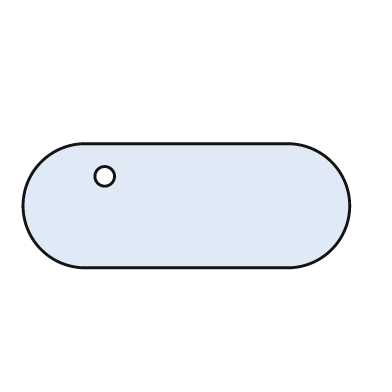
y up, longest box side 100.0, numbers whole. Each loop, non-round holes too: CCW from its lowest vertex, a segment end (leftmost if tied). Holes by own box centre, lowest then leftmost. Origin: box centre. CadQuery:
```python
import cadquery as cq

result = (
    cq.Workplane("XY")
    .moveTo(-31.0, -19.0)
    .lineTo(31.0, -19.0)
    .threePointArc((50.0, 0.0), (31.0, 19.0))
    .lineTo(-31.0, 19.0)
    .threePointArc((-50.0, 0.0), (-31.0, -19.0))
    .close()
    .moveTo(-25.0, 9.0)
    .circle(3.0)
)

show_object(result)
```